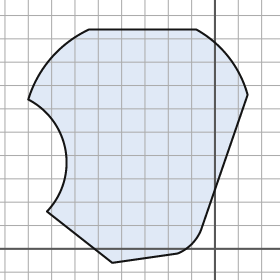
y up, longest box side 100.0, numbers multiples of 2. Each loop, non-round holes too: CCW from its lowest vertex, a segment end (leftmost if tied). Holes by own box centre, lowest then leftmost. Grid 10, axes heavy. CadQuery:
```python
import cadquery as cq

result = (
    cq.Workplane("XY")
    .moveTo(-44.0, -6.0)
    .lineTo(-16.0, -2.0)
    .threePointArc((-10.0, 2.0), (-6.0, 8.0))
    .lineTo(14.0, 66.0)
    .threePointArc((6.0, 82.0), (-8.0, 94.0))
    .lineTo(-54.0, 94.0)
    .threePointArc((-70.0, 82.0), (-80.0, 64.0))
    .threePointArc((-64.0, 42.0), (-72.0, 16.0))
    .close()
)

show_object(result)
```